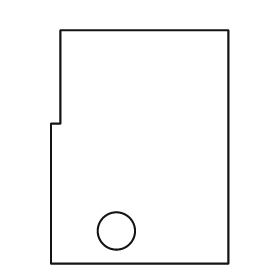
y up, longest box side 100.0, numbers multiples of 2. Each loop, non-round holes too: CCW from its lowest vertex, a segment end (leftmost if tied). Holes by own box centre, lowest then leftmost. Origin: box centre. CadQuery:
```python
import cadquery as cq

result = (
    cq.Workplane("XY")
    .moveTo(-38.0, -50.0)
    .lineTo(38.0, -50.0)
    .lineTo(38.0, 50.0)
    .lineTo(-34.0, 50.0)
    .lineTo(-34.0, 10.0)
    .lineTo(-38.0, 10.0)
    .close()
    .moveTo(-10.0, -36.0)
    .circle(8.0)
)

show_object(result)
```